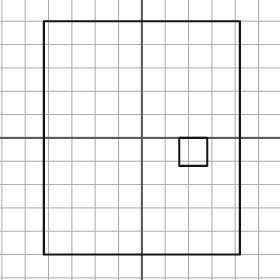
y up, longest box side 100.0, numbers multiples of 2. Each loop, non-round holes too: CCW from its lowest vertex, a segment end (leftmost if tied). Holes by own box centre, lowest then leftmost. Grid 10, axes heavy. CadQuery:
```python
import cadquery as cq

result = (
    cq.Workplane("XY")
    .moveTo(-42.0, -50.0)
    .lineTo(42.0, -50.0)
    .lineTo(42.0, 50.0)
    .lineTo(-42.0, 50.0)
    .close()
    .moveTo(16.0, -12.0)
    .lineTo(28.0, -12.0)
    .lineTo(28.0, 0.0)
    .lineTo(16.0, 0.0)
    .close()
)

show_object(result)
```